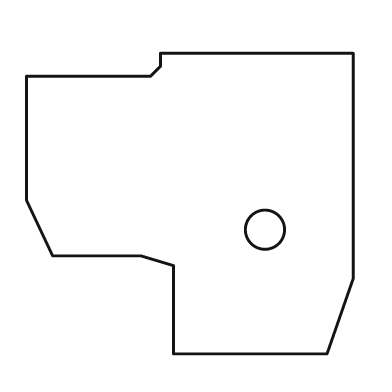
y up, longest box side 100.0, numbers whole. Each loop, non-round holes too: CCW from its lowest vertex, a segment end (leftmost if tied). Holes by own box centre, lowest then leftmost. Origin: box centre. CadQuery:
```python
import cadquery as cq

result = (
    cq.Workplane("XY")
    .moveTo(-5.0, -46.0)
    .lineTo(42.0, -46.0)
    .lineTo(50.0, -23.0)
    .lineTo(50.0, 46.0)
    .lineTo(-9.0, 46.0)
    .lineTo(-9.0, 42.0)
    .lineTo(-12.0, 39.0)
    .lineTo(-50.0, 39.0)
    .lineTo(-50.0, 1.0)
    .lineTo(-42.0, -16.0)
    .lineTo(-15.0, -16.0)
    .lineTo(-5.0, -19.0)
    .close()
    .moveTo(23.0, -8.0)
    .circle(6.0)
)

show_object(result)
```